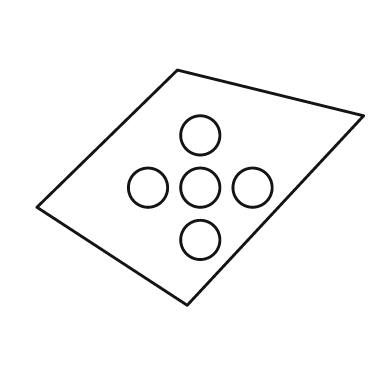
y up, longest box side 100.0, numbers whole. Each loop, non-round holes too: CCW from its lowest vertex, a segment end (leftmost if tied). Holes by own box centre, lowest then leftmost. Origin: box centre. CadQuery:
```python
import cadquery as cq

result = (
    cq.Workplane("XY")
    .moveTo(-4.0, -36.0)
    .lineTo(50.0, 22.0)
    .lineTo(-7.0, 36.0)
    .lineTo(-50.0, -6.0)
    .close()
    .moveTo(0.0, -16.0)
    .circle(6.0)
    .moveTo(-16.0, 0.0)
    .circle(6.0)
    .moveTo(0.0, 0.0)
    .circle(6.0)
    .moveTo(16.0, 0.0)
    .circle(6.0)
    .moveTo(0.0, 16.0)
    .circle(6.0)
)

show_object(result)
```